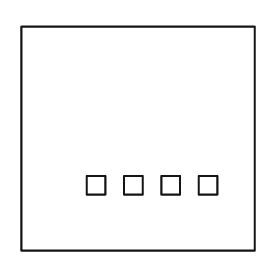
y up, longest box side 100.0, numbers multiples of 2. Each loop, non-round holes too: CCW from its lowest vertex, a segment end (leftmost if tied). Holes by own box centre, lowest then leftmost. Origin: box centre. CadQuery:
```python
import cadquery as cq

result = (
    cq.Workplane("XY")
    .moveTo(-50.0, -48.0)
    .lineTo(50.0, -48.0)
    .lineTo(50.0, 48.0)
    .lineTo(-50.0, 48.0)
    .close()
    .moveTo(-22.0, -24.0)
    .lineTo(-14.0, -24.0)
    .lineTo(-14.0, -16.0)
    .lineTo(-22.0, -16.0)
    .close()
    .moveTo(-6.0, -24.0)
    .lineTo(2.0, -24.0)
    .lineTo(2.0, -16.0)
    .lineTo(-6.0, -16.0)
    .close()
    .moveTo(10.0, -24.0)
    .lineTo(18.0, -24.0)
    .lineTo(18.0, -16.0)
    .lineTo(10.0, -16.0)
    .close()
    .moveTo(26.0, -24.0)
    .lineTo(34.0, -24.0)
    .lineTo(34.0, -16.0)
    .lineTo(26.0, -16.0)
    .close()
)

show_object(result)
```